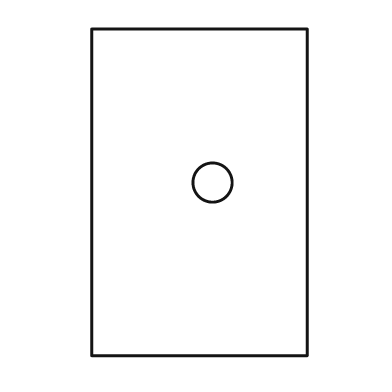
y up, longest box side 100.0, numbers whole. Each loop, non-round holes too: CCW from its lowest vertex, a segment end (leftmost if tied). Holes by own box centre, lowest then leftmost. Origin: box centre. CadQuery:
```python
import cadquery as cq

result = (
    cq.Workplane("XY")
    .moveTo(-33.0, -50.0)
    .lineTo(33.0, -50.0)
    .lineTo(33.0, 50.0)
    .lineTo(-33.0, 50.0)
    .close()
    .moveTo(4.0, 3.0)
    .circle(6.0)
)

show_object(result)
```